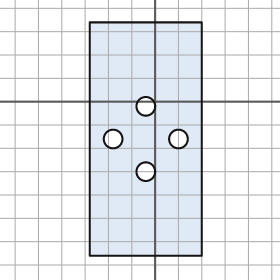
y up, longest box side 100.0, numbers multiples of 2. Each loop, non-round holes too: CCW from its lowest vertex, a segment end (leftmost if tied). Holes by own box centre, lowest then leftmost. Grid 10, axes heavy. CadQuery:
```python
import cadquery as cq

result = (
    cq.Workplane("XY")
    .moveTo(-28.0, -66.0)
    .lineTo(20.0, -66.0)
    .lineTo(20.0, 34.0)
    .lineTo(-28.0, 34.0)
    .close()
    .moveTo(-4.0, -30.0)
    .circle(4.0)
    .moveTo(-18.0, -16.0)
    .circle(4.0)
    .moveTo(10.0, -16.0)
    .circle(4.0)
    .moveTo(-4.0, -2.0)
    .circle(4.0)
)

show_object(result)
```